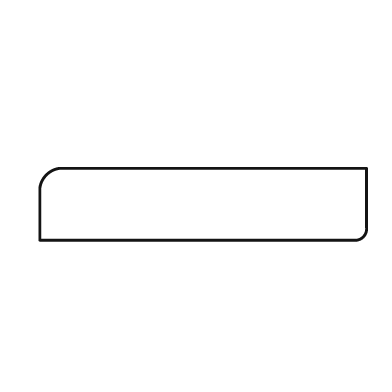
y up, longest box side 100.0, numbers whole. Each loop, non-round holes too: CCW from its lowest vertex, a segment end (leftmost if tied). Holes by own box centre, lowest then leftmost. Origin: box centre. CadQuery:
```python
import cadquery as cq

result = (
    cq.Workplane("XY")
    .moveTo(-50.0, -11.0)
    .lineTo(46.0, -11.0)
    .threePointArc((49.0, -10.0), (50.0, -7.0))
    .lineTo(50.0, 11.0)
    .lineTo(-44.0, 11.0)
    .threePointArc((-48.0, 9.0), (-50.0, 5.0))
    .close()
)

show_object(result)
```